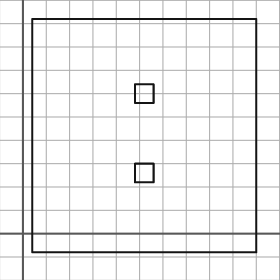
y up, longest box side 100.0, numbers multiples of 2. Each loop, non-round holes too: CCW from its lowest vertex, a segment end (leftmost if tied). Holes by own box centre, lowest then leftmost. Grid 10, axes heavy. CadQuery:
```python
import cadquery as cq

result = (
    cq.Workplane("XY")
    .moveTo(4.0, -8.0)
    .lineTo(100.0, -8.0)
    .lineTo(100.0, 92.0)
    .lineTo(4.0, 92.0)
    .close()
    .moveTo(48.0, 22.0)
    .lineTo(56.0, 22.0)
    .lineTo(56.0, 30.0)
    .lineTo(48.0, 30.0)
    .close()
    .moveTo(48.0, 56.0)
    .lineTo(56.0, 56.0)
    .lineTo(56.0, 64.0)
    .lineTo(48.0, 64.0)
    .close()
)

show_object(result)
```